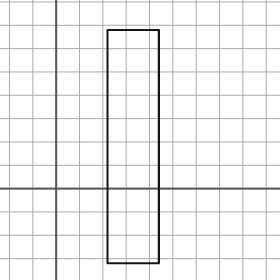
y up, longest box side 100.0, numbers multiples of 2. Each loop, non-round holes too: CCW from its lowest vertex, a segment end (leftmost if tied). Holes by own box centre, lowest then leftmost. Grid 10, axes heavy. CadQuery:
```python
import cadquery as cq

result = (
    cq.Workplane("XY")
    .moveTo(22.0, -32.0)
    .lineTo(44.0, -32.0)
    .lineTo(44.0, 68.0)
    .lineTo(22.0, 68.0)
    .close()
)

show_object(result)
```